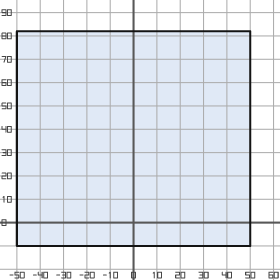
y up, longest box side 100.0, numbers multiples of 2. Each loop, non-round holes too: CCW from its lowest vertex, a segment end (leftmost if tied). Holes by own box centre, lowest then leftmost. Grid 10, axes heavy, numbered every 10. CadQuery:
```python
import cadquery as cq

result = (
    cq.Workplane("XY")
    .moveTo(-50.0, -10.0)
    .lineTo(50.0, -10.0)
    .lineTo(50.0, 82.0)
    .lineTo(-50.0, 82.0)
    .close()
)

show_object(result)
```